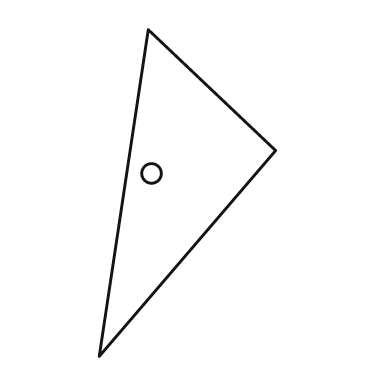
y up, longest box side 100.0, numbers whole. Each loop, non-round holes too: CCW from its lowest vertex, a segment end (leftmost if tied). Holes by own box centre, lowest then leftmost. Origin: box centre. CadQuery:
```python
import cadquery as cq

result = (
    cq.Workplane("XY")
    .moveTo(-27.0, -50.0)
    .lineTo(27.0, 13.0)
    .lineTo(-12.0, 50.0)
    .close()
    .moveTo(-11.0, 6.0)
    .circle(3.0)
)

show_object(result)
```